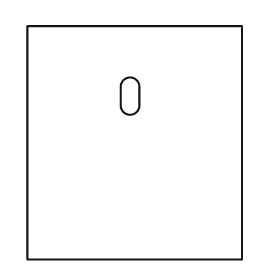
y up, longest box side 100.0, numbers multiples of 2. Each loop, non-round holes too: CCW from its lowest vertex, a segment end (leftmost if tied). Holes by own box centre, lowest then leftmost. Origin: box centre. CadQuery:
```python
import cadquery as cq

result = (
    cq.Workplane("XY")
    .moveTo(-46.0, -50.0)
    .lineTo(46.0, -50.0)
    .lineTo(46.0, 50.0)
    .lineTo(-46.0, 50.0)
    .close()
    .moveTo(-6.0, 16.0)
    .threePointArc((-2.0, 12.0), (2.0, 16.0))
    .lineTo(2.0, 24.0)
    .threePointArc((-2.0, 28.0), (-6.0, 24.0))
    .close()
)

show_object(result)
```